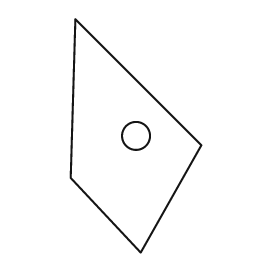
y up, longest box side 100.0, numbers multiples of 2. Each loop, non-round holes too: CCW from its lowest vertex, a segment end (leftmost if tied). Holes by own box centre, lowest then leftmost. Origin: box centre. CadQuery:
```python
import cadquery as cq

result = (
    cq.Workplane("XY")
    .moveTo(2.0, -50.0)
    .lineTo(28.0, -4.0)
    .lineTo(-26.0, 50.0)
    .lineTo(-28.0, -18.0)
    .close()
    .moveTo(0.0, 0.0)
    .circle(6.0)
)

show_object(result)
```